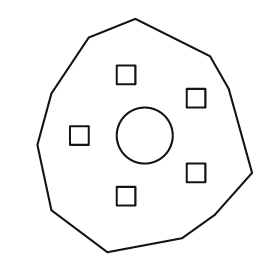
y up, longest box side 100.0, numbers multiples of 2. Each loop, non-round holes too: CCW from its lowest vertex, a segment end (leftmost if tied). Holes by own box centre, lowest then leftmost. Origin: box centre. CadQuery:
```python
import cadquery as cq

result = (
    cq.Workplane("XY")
    .moveTo(-16.0, -50.0)
    .lineTo(16.0, -44.0)
    .lineTo(30.0, -34.0)
    .lineTo(46.0, -16.0)
    .lineTo(36.0, 20.0)
    .lineTo(28.0, 34.0)
    .lineTo(-4.0, 50.0)
    .lineTo(-24.0, 42.0)
    .lineTo(-40.0, 18.0)
    .lineTo(-46.0, -4.0)
    .lineTo(-40.0, -32.0)
    .close()
    .moveTo(-12.0, -30.0)
    .lineTo(-4.0, -30.0)
    .lineTo(-4.0, -22.0)
    .lineTo(-12.0, -22.0)
    .close()
    .moveTo(18.0, -20.0)
    .lineTo(26.0, -20.0)
    .lineTo(26.0, -12.0)
    .lineTo(18.0, -12.0)
    .close()
    .moveTo(-32.0, -4.0)
    .lineTo(-24.0, -4.0)
    .lineTo(-24.0, 4.0)
    .lineTo(-32.0, 4.0)
    .close()
    .moveTo(0.0, 0.0)
    .circle(12.0)
    .moveTo(18.0, 12.0)
    .lineTo(26.0, 12.0)
    .lineTo(26.0, 20.0)
    .lineTo(18.0, 20.0)
    .close()
    .moveTo(-12.0, 22.0)
    .lineTo(-4.0, 22.0)
    .lineTo(-4.0, 30.0)
    .lineTo(-12.0, 30.0)
    .close()
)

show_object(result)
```